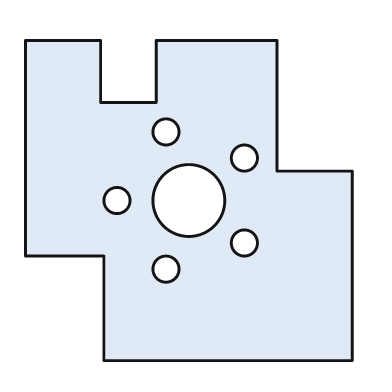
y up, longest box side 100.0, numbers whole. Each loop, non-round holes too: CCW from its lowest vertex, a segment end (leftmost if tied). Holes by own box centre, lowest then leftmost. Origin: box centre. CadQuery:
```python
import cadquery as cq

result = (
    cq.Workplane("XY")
    .moveTo(-26.0, -49.0)
    .lineTo(50.0, -49.0)
    .lineTo(50.0, 9.0)
    .lineTo(27.0, 9.0)
    .lineTo(27.0, 49.0)
    .lineTo(-10.0, 49.0)
    .lineTo(-10.0, 30.0)
    .lineTo(-27.0, 30.0)
    .lineTo(-27.0, 49.0)
    .lineTo(-50.0, 49.0)
    .lineTo(-50.0, -17.0)
    .lineTo(-26.0, -17.0)
    .close()
    .moveTo(-7.0, -21.0)
    .circle(4.0)
    .moveTo(17.0, -13.0)
    .circle(4.0)
    .moveTo(-22.0, 0.0)
    .circle(4.0)
    .moveTo(0.0, 0.0)
    .circle(11.0)
    .moveTo(17.0, 13.0)
    .circle(4.0)
    .moveTo(-7.0, 21.0)
    .circle(4.0)
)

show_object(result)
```